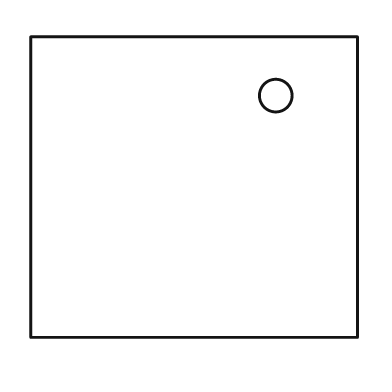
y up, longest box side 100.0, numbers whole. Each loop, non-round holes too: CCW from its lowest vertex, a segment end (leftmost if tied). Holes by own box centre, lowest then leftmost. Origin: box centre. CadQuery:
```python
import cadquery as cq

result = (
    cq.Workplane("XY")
    .moveTo(-50.0, -46.0)
    .lineTo(50.0, -46.0)
    .lineTo(50.0, 46.0)
    .lineTo(-50.0, 46.0)
    .close()
    .moveTo(25.0, 28.0)
    .circle(5.0)
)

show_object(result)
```